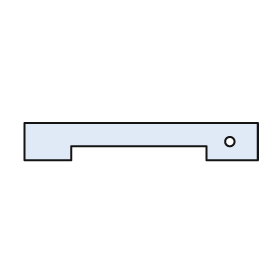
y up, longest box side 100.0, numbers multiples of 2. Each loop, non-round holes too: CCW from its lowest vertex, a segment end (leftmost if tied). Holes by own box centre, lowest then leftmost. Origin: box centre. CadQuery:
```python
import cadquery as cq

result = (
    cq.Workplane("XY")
    .moveTo(-50.0, -8.0)
    .lineTo(-30.0, -8.0)
    .lineTo(-30.0, -2.0)
    .lineTo(28.0, -2.0)
    .lineTo(28.0, -8.0)
    .lineTo(50.0, -8.0)
    .lineTo(50.0, 8.0)
    .lineTo(-50.0, 8.0)
    .close()
    .moveTo(38.0, 0.0)
    .circle(2.0)
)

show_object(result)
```